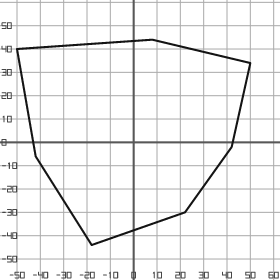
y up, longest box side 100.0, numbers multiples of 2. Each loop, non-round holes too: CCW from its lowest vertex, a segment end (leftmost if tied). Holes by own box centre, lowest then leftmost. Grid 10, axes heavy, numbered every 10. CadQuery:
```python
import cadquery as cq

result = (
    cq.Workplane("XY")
    .moveTo(-18.0, -44.0)
    .lineTo(22.0, -30.0)
    .lineTo(42.0, -2.0)
    .lineTo(50.0, 34.0)
    .lineTo(8.0, 44.0)
    .lineTo(-50.0, 40.0)
    .lineTo(-42.0, -6.0)
    .close()
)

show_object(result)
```